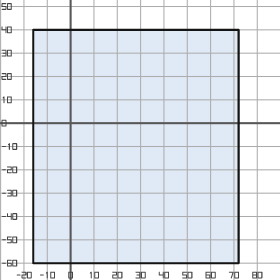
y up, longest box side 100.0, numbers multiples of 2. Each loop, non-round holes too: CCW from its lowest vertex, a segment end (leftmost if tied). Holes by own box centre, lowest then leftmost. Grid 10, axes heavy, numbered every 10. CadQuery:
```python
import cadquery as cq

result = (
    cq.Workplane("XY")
    .moveTo(-16.0, -60.0)
    .lineTo(72.0, -60.0)
    .lineTo(72.0, 40.0)
    .lineTo(-16.0, 40.0)
    .close()
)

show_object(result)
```